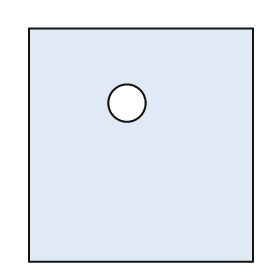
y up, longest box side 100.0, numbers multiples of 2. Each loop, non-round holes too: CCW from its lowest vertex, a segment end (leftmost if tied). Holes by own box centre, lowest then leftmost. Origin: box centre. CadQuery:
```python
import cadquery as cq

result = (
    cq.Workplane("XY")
    .moveTo(-48.0, -50.0)
    .lineTo(48.0, -50.0)
    .lineTo(48.0, 50.0)
    .lineTo(-48.0, 50.0)
    .close()
    .moveTo(-6.0, 18.0)
    .circle(8.0)
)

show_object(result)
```